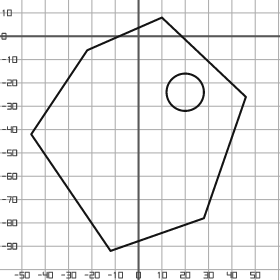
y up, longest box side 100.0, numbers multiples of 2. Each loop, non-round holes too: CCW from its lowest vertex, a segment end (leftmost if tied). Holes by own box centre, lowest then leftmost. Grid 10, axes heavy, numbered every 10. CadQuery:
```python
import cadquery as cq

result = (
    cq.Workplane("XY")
    .moveTo(-12.0, -92.0)
    .lineTo(28.0, -78.0)
    .lineTo(46.0, -26.0)
    .lineTo(10.0, 8.0)
    .lineTo(-22.0, -6.0)
    .lineTo(-46.0, -42.0)
    .close()
    .moveTo(20.0, -24.0)
    .circle(8.0)
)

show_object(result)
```